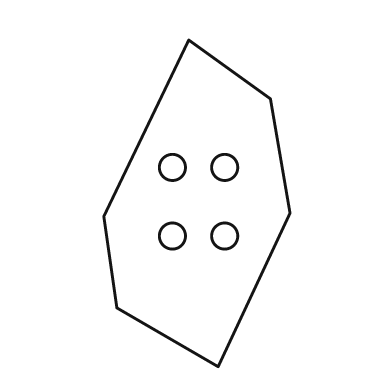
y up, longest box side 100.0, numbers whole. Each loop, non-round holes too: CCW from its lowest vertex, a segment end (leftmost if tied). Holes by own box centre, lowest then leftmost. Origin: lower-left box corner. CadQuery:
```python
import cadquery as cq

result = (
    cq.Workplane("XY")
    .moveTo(35.0, 0.0)
    .lineTo(57.0, 47.0)
    .lineTo(51.0, 82.0)
    .lineTo(26.0, 100.0)
    .lineTo(0.0, 46.0)
    .lineTo(4.0, 18.0)
    .close()
    .moveTo(21.0, 40.0)
    .circle(4.0)
    .moveTo(37.0, 40.0)
    .circle(4.0)
    .moveTo(21.0, 61.0)
    .circle(4.0)
    .moveTo(37.0, 61.0)
    .circle(4.0)
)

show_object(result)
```